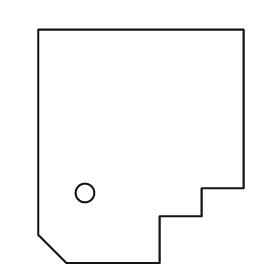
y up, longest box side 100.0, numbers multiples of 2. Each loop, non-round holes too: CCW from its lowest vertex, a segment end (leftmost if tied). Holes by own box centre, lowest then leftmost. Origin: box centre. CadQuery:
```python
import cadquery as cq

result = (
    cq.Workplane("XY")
    .moveTo(-32.0, -50.0)
    .lineTo(8.0, -50.0)
    .lineTo(8.0, -30.0)
    .lineTo(26.0, -30.0)
    .lineTo(26.0, -18.0)
    .lineTo(44.0, -18.0)
    .lineTo(44.0, 50.0)
    .lineTo(-44.0, 50.0)
    .lineTo(-44.0, -38.0)
    .close()
    .moveTo(-24.0, -20.0)
    .circle(4.0)
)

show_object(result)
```